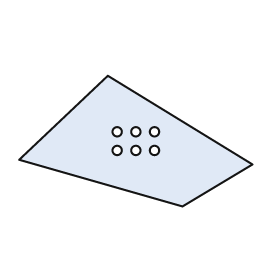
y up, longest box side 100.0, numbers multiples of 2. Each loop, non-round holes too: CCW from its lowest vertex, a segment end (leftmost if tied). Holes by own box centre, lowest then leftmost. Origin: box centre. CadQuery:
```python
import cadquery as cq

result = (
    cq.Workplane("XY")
    .moveTo(20.0, -28.0)
    .lineTo(50.0, -10.0)
    .lineTo(-12.0, 28.0)
    .lineTo(-50.0, -8.0)
    .close()
    .moveTo(-8.0, -4.0)
    .circle(2.0)
    .moveTo(0.0, -4.0)
    .circle(2.0)
    .moveTo(8.0, -4.0)
    .circle(2.0)
    .moveTo(-8.0, 4.0)
    .circle(2.0)
    .moveTo(0.0, 4.0)
    .circle(2.0)
    .moveTo(8.0, 4.0)
    .circle(2.0)
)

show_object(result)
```